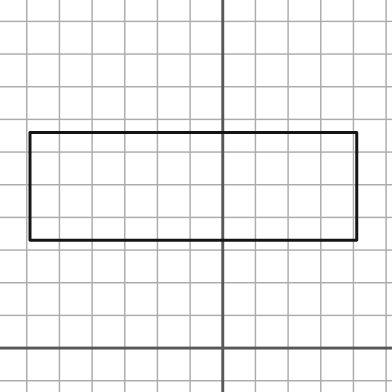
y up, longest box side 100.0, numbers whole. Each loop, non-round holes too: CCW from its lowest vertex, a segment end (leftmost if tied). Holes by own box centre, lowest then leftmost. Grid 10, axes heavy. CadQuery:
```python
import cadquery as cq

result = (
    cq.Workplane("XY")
    .moveTo(-59.0, 33.0)
    .lineTo(41.0, 33.0)
    .lineTo(41.0, 66.0)
    .lineTo(-59.0, 66.0)
    .close()
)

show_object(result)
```